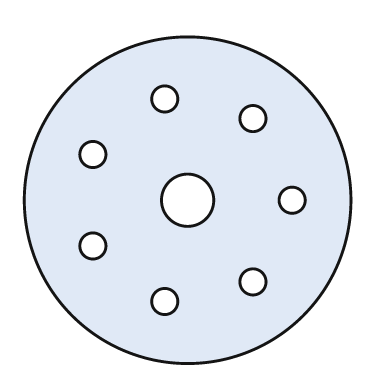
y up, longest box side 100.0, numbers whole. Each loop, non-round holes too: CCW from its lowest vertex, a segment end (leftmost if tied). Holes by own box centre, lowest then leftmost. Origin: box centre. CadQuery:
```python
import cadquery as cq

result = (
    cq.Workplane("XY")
    .moveTo(0.0, 0.0)
    .circle(50.0)
    .moveTo(-7.0, -31.0)
    .circle(4.0)
    .moveTo(20.0, -25.0)
    .circle(4.0)
    .moveTo(-29.0, -14.0)
    .circle(4.0)
    .moveTo(0.0, 0.0)
    .circle(8.0)
    .moveTo(32.0, 0.0)
    .circle(4.0)
    .moveTo(-29.0, 14.0)
    .circle(4.0)
    .moveTo(20.0, 25.0)
    .circle(4.0)
    .moveTo(-7.0, 31.0)
    .circle(4.0)
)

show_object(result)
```